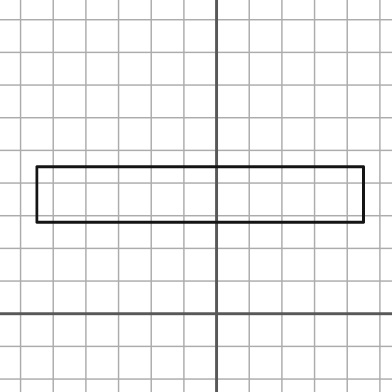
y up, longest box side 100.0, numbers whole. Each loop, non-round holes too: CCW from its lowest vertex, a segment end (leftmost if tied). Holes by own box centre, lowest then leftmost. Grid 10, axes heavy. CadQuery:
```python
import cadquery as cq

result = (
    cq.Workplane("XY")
    .moveTo(-55.0, 28.0)
    .lineTo(45.0, 28.0)
    .lineTo(45.0, 45.0)
    .lineTo(-55.0, 45.0)
    .close()
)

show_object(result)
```